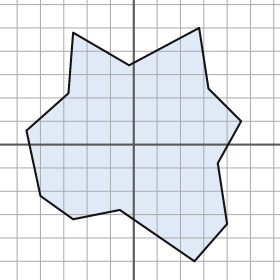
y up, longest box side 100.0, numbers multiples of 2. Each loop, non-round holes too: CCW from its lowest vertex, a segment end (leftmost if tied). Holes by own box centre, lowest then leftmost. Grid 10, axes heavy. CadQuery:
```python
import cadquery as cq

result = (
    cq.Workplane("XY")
    .moveTo(26.0, -50.0)
    .lineTo(40.0, -34.0)
    .lineTo(36.0, -8.0)
    .lineTo(46.0, 10.0)
    .lineTo(32.0, 24.0)
    .lineTo(28.0, 50.0)
    .lineTo(-2.0, 34.0)
    .lineTo(-26.0, 48.0)
    .lineTo(-28.0, 22.0)
    .lineTo(-46.0, 6.0)
    .lineTo(-40.0, -22.0)
    .lineTo(-26.0, -32.0)
    .lineTo(-6.0, -28.0)
    .close()
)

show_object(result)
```